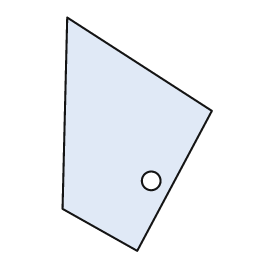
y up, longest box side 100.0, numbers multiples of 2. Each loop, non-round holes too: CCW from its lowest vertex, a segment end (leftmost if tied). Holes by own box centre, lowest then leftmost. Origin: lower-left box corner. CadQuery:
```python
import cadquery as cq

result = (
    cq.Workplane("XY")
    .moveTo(32.0, 0.0)
    .lineTo(64.0, 60.0)
    .lineTo(2.0, 100.0)
    .lineTo(0.0, 18.0)
    .close()
    .moveTo(38.0, 30.0)
    .circle(4.0)
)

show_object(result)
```